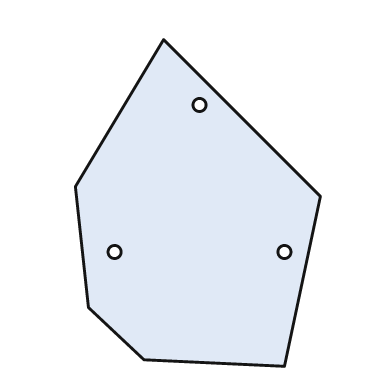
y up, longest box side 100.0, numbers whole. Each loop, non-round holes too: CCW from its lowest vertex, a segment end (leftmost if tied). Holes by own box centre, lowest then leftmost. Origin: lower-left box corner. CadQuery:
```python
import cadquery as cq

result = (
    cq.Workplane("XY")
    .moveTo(64.0, 0.0)
    .lineTo(75.0, 52.0)
    .lineTo(27.0, 100.0)
    .lineTo(0.0, 55.0)
    .lineTo(4.0, 18.0)
    .lineTo(21.0, 2.0)
    .close()
    .moveTo(12.0, 35.0)
    .circle(2.0)
    .moveTo(64.0, 35.0)
    .circle(2.0)
    .moveTo(38.0, 80.0)
    .circle(2.0)
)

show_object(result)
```